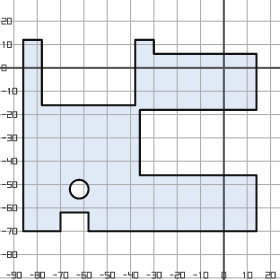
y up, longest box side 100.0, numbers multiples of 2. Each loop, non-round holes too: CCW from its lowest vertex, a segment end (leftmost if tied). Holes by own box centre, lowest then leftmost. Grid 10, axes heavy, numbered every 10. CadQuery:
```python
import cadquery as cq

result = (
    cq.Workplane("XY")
    .moveTo(-86.0, -70.0)
    .lineTo(-70.0, -70.0)
    .lineTo(-70.0, -62.0)
    .lineTo(-58.0, -62.0)
    .lineTo(-58.0, -70.0)
    .lineTo(14.0, -70.0)
    .lineTo(14.0, -46.0)
    .lineTo(-36.0, -46.0)
    .lineTo(-36.0, -18.0)
    .lineTo(14.0, -18.0)
    .lineTo(14.0, 6.0)
    .lineTo(-30.0, 6.0)
    .lineTo(-30.0, 12.0)
    .lineTo(-38.0, 12.0)
    .lineTo(-38.0, -16.0)
    .lineTo(-78.0, -16.0)
    .lineTo(-78.0, 12.0)
    .lineTo(-86.0, 12.0)
    .close()
    .moveTo(-62.0, -52.0)
    .circle(4.0)
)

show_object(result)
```